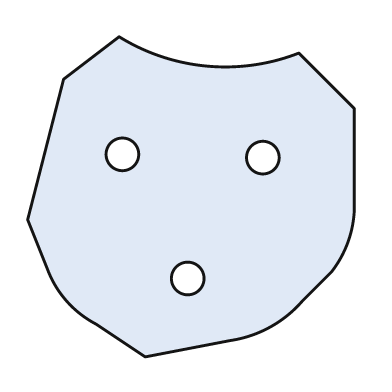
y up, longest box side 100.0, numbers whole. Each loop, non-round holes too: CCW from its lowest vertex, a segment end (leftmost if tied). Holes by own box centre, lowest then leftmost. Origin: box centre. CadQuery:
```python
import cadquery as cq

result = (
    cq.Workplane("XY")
    .moveTo(-14.0, -49.0)
    .lineTo(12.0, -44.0)
    .threePointArc((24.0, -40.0), (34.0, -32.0))
    .lineTo(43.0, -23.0)
    .threePointArc((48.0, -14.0), (50.0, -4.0))
    .lineTo(50.0, 27.0)
    .lineTo(33.0, 44.0)
    .threePointArc((5.0, 40.0), (-22.0, 49.0))
    .lineTo(-39.0, 36.0)
    .lineTo(-50.0, -7.0)
    .lineTo(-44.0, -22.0)
    .threePointArc((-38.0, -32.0), (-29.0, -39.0))
    .close()
    .moveTo(-1.0, -25.0)
    .circle(5.0)
    .moveTo(22.0, 12.0)
    .circle(5.0)
    .moveTo(-21.0, 13.0)
    .circle(5.0)
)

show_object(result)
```